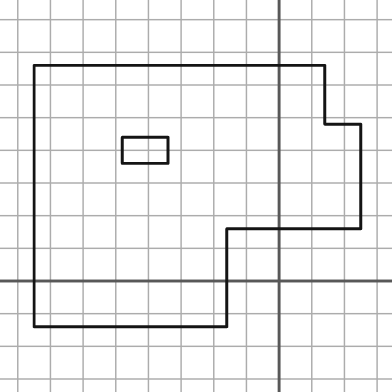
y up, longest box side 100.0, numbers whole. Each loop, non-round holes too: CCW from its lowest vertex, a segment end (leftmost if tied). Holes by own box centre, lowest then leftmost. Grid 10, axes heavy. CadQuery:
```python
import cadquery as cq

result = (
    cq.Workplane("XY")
    .moveTo(-75.0, -14.0)
    .lineTo(-16.0, -14.0)
    .lineTo(-16.0, 16.0)
    .lineTo(25.0, 16.0)
    .lineTo(25.0, 48.0)
    .lineTo(14.0, 48.0)
    .lineTo(14.0, 66.0)
    .lineTo(-75.0, 66.0)
    .close()
    .moveTo(-48.0, 36.0)
    .lineTo(-34.0, 36.0)
    .lineTo(-34.0, 44.0)
    .lineTo(-48.0, 44.0)
    .close()
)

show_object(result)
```